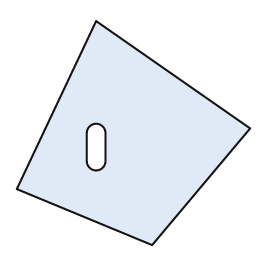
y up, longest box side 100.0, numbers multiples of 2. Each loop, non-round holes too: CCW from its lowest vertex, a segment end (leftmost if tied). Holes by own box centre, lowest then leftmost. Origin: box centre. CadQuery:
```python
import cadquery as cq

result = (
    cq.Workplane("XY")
    .moveTo(8.0, -48.0)
    .lineTo(50.0, 2.0)
    .lineTo(-16.0, 48.0)
    .lineTo(-50.0, -24.0)
    .close()
    .moveTo(-20.0, -12.0)
    .threePointArc((-16.0, -16.0), (-12.0, -12.0))
    .lineTo(-12.0, 0.0)
    .threePointArc((-16.0, 4.0), (-20.0, 0.0))
    .close()
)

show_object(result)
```